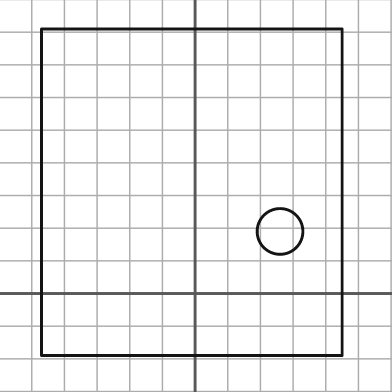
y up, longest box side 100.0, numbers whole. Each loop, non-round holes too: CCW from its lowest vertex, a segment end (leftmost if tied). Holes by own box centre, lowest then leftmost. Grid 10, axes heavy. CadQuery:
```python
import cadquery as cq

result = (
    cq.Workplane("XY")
    .moveTo(-47.0, -19.0)
    .lineTo(45.0, -19.0)
    .lineTo(45.0, 81.0)
    .lineTo(-47.0, 81.0)
    .close()
    .moveTo(26.0, 19.0)
    .circle(7.0)
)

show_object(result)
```